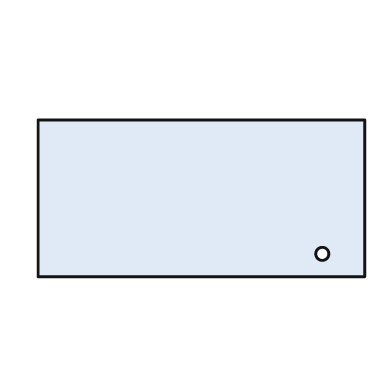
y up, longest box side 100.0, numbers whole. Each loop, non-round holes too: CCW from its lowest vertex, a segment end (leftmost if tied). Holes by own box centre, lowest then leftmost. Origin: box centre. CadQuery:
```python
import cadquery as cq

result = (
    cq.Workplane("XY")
    .moveTo(-50.0, -24.0)
    .lineTo(50.0, -24.0)
    .lineTo(50.0, 24.0)
    .lineTo(-50.0, 24.0)
    .close()
    .moveTo(37.0, -17.0)
    .circle(2.0)
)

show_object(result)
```